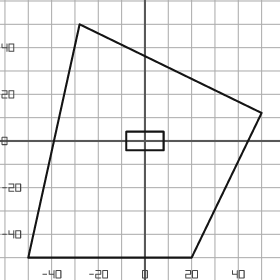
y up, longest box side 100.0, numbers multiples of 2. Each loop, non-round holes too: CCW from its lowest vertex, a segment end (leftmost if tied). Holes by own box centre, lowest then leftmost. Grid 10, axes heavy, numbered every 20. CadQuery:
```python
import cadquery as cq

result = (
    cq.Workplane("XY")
    .moveTo(-50.0, -50.0)
    .lineTo(20.0, -50.0)
    .lineTo(50.0, 12.0)
    .lineTo(-28.0, 50.0)
    .close()
    .moveTo(-8.0, -4.0)
    .lineTo(8.0, -4.0)
    .lineTo(8.0, 4.0)
    .lineTo(-8.0, 4.0)
    .close()
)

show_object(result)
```